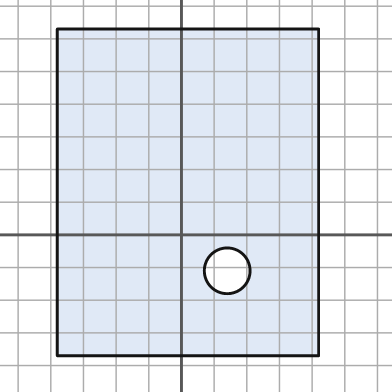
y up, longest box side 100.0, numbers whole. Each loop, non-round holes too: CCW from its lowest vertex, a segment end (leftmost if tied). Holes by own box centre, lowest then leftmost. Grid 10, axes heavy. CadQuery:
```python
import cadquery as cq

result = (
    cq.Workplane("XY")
    .moveTo(-38.0, -37.0)
    .lineTo(42.0, -37.0)
    .lineTo(42.0, 63.0)
    .lineTo(-38.0, 63.0)
    .close()
    .moveTo(14.0, -11.0)
    .circle(7.0)
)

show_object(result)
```